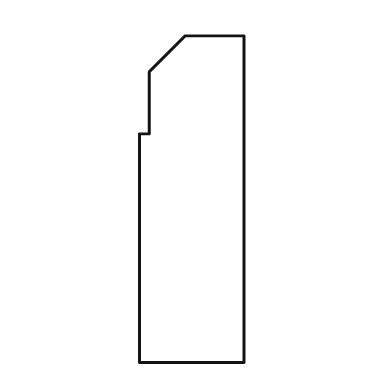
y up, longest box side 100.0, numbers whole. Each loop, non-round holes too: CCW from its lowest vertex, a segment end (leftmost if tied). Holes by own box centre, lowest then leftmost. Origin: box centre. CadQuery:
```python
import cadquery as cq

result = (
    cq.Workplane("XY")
    .moveTo(-16.0, -50.0)
    .lineTo(16.0, -50.0)
    .lineTo(16.0, 50.0)
    .lineTo(-2.0, 50.0)
    .lineTo(-13.0, 39.0)
    .lineTo(-13.0, 20.0)
    .lineTo(-16.0, 20.0)
    .close()
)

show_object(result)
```